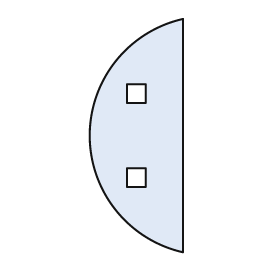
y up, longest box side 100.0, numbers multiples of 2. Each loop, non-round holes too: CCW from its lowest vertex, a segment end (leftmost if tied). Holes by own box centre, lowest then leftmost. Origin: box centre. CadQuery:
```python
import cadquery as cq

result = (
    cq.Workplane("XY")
    .moveTo(20.0, -50.0)
    .lineTo(20.0, 50.0)
    .threePointArc((-20.0, 0.0), (20.0, -50.0))
    .close()
    .moveTo(-4.0, -22.0)
    .lineTo(4.0, -22.0)
    .lineTo(4.0, -14.0)
    .lineTo(-4.0, -14.0)
    .close()
    .moveTo(-4.0, 14.0)
    .lineTo(4.0, 14.0)
    .lineTo(4.0, 22.0)
    .lineTo(-4.0, 22.0)
    .close()
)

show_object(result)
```